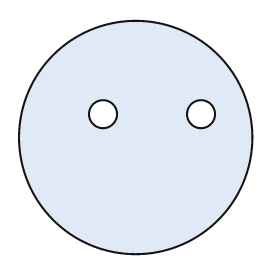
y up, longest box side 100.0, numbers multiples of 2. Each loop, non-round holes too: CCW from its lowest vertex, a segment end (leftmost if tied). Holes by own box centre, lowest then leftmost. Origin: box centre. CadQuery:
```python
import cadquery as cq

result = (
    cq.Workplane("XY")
    .moveTo(0.0, 0.0)
    .circle(50.0)
    .moveTo(-14.0, 10.0)
    .circle(6.0)
    .moveTo(28.0, 10.0)
    .circle(6.0)
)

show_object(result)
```